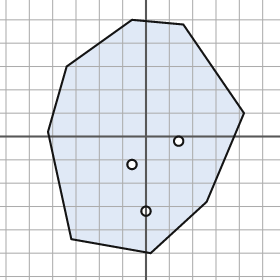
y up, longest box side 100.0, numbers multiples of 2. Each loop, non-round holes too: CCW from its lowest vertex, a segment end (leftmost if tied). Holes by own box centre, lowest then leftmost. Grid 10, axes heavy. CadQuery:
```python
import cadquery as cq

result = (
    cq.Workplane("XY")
    .moveTo(2.0, -50.0)
    .lineTo(26.0, -28.0)
    .lineTo(42.0, 10.0)
    .lineTo(16.0, 48.0)
    .lineTo(-6.0, 50.0)
    .lineTo(-34.0, 30.0)
    .lineTo(-42.0, 2.0)
    .lineTo(-32.0, -44.0)
    .close()
    .moveTo(0.0, -32.0)
    .circle(2.0)
    .moveTo(-6.0, -12.0)
    .circle(2.0)
    .moveTo(14.0, -2.0)
    .circle(2.0)
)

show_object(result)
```